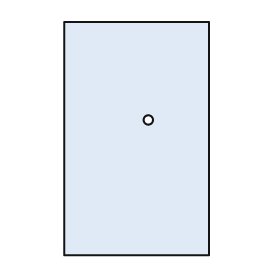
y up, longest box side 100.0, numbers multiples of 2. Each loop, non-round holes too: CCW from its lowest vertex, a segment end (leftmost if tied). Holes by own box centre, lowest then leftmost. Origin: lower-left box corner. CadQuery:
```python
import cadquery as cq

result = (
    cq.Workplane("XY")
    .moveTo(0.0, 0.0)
    .lineTo(62.0, 0.0)
    .lineTo(62.0, 100.0)
    .lineTo(0.0, 100.0)
    .close()
    .moveTo(36.0, 58.0)
    .circle(2.0)
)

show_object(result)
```